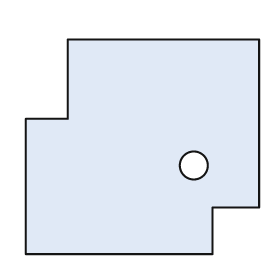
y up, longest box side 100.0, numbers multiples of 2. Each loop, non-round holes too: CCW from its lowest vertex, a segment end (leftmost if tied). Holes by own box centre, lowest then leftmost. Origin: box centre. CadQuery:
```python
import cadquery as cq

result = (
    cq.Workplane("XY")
    .moveTo(-50.0, -46.0)
    .lineTo(30.0, -46.0)
    .lineTo(30.0, -26.0)
    .lineTo(50.0, -26.0)
    .lineTo(50.0, 46.0)
    .lineTo(-32.0, 46.0)
    .lineTo(-32.0, 12.0)
    .lineTo(-50.0, 12.0)
    .close()
    .moveTo(22.0, -8.0)
    .circle(6.0)
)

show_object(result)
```